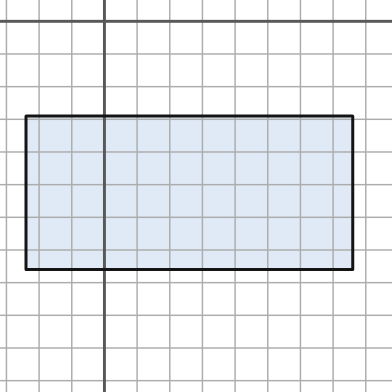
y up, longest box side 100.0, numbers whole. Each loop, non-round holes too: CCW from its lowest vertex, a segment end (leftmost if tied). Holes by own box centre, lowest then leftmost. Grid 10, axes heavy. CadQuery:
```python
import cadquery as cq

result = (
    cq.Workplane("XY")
    .moveTo(-24.0, -76.0)
    .lineTo(76.0, -76.0)
    .lineTo(76.0, -29.0)
    .lineTo(-24.0, -29.0)
    .close()
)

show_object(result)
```